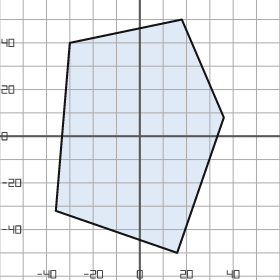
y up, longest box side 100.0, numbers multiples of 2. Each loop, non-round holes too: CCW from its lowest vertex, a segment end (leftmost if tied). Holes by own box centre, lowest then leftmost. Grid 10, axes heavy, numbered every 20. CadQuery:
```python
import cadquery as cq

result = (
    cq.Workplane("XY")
    .moveTo(16.0, -50.0)
    .lineTo(36.0, 8.0)
    .lineTo(18.0, 50.0)
    .lineTo(-30.0, 40.0)
    .lineTo(-36.0, -32.0)
    .close()
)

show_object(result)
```